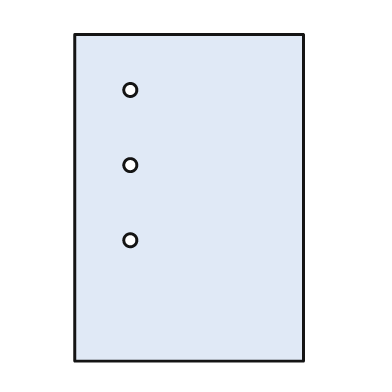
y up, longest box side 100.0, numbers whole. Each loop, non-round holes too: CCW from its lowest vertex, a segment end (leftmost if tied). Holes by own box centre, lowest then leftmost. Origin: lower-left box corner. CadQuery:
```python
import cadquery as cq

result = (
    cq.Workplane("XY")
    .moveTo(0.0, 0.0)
    .lineTo(70.0, 0.0)
    .lineTo(70.0, 100.0)
    .lineTo(0.0, 100.0)
    .close()
    .moveTo(17.0, 37.0)
    .circle(2.0)
    .moveTo(17.0, 60.0)
    .circle(2.0)
    .moveTo(17.0, 83.0)
    .circle(2.0)
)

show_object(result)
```